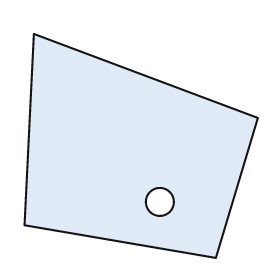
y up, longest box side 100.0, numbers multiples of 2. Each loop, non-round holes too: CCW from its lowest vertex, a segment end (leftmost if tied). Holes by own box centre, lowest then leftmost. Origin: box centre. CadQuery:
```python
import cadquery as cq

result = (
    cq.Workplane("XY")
    .moveTo(32.0, -48.0)
    .lineTo(50.0, 12.0)
    .lineTo(-46.0, 48.0)
    .lineTo(-50.0, -34.0)
    .close()
    .moveTo(8.0, -24.0)
    .circle(6.0)
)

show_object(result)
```